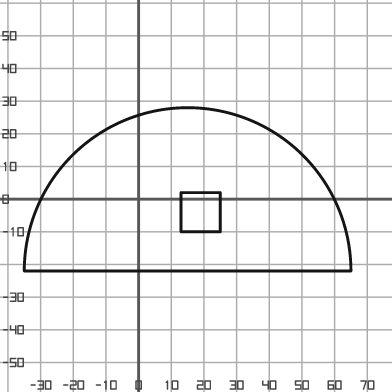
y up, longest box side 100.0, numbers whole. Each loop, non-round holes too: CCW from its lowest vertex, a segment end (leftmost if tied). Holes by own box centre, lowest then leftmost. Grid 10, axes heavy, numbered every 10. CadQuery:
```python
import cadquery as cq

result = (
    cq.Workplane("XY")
    .moveTo(-35.0, -22.0)
    .lineTo(65.0, -22.0)
    .threePointArc((15.0, 28.0), (-35.0, -22.0))
    .close()
    .moveTo(13.0, -10.0)
    .lineTo(25.0, -10.0)
    .lineTo(25.0, 2.0)
    .lineTo(13.0, 2.0)
    .close()
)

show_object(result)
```